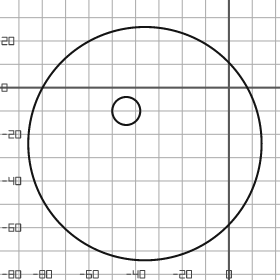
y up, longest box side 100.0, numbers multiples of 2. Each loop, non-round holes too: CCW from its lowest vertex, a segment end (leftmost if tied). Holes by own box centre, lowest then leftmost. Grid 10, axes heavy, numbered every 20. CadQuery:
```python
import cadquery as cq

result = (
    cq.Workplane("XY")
    .moveTo(-36.0, -24.0)
    .circle(50.0)
    .moveTo(-44.0, -10.0)
    .circle(6.0)
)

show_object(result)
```